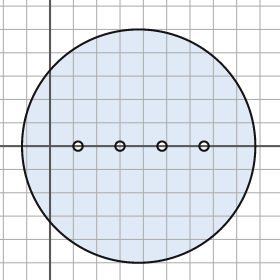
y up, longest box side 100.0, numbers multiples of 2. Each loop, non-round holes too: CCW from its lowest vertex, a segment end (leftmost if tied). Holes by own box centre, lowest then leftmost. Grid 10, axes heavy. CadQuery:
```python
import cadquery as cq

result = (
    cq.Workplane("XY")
    .moveTo(38.0, 0.0)
    .circle(50.0)
    .moveTo(12.0, 0.0)
    .circle(2.0)
    .moveTo(30.0, 0.0)
    .circle(2.0)
    .moveTo(48.0, 0.0)
    .circle(2.0)
    .moveTo(66.0, 0.0)
    .circle(2.0)
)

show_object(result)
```